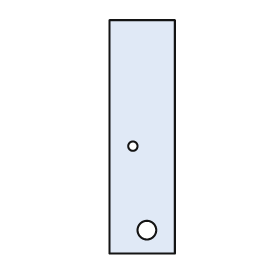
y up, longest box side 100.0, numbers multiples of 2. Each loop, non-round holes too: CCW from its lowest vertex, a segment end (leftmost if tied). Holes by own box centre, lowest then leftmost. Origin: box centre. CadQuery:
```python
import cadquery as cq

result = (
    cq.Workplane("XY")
    .moveTo(-14.0, -50.0)
    .lineTo(14.0, -50.0)
    .lineTo(14.0, 50.0)
    .lineTo(-14.0, 50.0)
    .close()
    .moveTo(2.0, -40.0)
    .circle(4.0)
    .moveTo(-4.0, -4.0)
    .circle(2.0)
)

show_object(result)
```